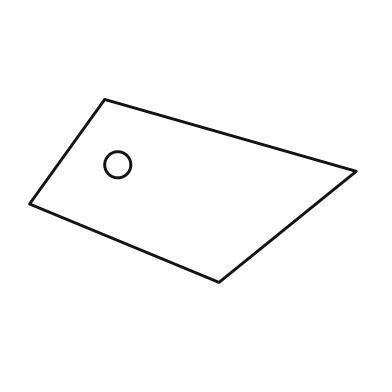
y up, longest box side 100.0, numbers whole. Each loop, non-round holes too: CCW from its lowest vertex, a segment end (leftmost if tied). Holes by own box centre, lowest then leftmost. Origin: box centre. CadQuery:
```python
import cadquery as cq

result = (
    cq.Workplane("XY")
    .moveTo(8.0, -28.0)
    .lineTo(50.0, 6.0)
    .lineTo(-27.0, 28.0)
    .lineTo(-50.0, -4.0)
    .close()
    .moveTo(-23.0, 8.0)
    .circle(4.0)
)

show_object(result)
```